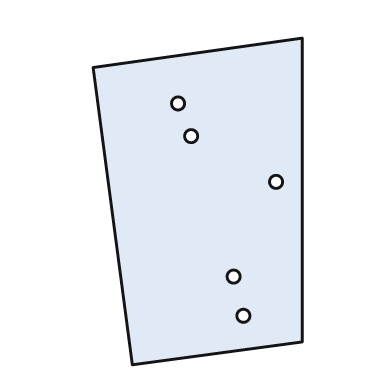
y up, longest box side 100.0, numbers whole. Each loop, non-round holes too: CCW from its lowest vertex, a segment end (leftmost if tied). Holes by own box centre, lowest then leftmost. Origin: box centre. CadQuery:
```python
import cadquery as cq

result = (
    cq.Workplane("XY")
    .moveTo(-20.0, -50.0)
    .lineTo(32.0, -43.0)
    .lineTo(32.0, 50.0)
    .lineTo(-32.0, 41.0)
    .close()
    .moveTo(14.0, -35.0)
    .circle(2.0)
    .moveTo(11.0, -23.0)
    .circle(2.0)
    .moveTo(24.0, 6.0)
    .circle(2.0)
    .moveTo(-2.0, 20.0)
    .circle(2.0)
    .moveTo(-6.0, 30.0)
    .circle(2.0)
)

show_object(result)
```